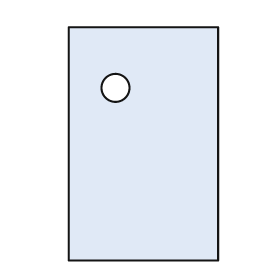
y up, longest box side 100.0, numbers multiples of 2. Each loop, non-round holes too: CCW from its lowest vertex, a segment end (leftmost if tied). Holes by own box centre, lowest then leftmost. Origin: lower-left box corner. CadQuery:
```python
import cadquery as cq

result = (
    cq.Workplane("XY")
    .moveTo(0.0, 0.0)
    .lineTo(64.0, 0.0)
    .lineTo(64.0, 100.0)
    .lineTo(0.0, 100.0)
    .close()
    .moveTo(20.0, 74.0)
    .circle(6.0)
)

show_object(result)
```